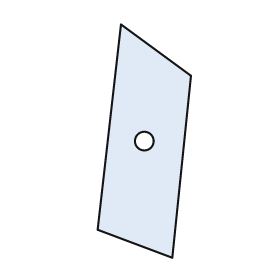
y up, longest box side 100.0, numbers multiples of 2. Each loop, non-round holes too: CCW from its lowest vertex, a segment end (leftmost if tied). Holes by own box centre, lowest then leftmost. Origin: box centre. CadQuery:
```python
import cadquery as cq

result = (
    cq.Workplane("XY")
    .moveTo(12.0, -50.0)
    .lineTo(20.0, 28.0)
    .lineTo(-10.0, 50.0)
    .lineTo(-20.0, -38.0)
    .close()
    .moveTo(0.0, 0.0)
    .circle(4.0)
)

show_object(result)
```